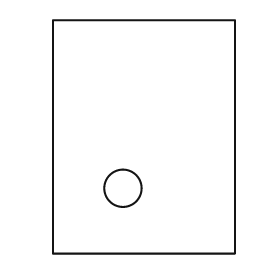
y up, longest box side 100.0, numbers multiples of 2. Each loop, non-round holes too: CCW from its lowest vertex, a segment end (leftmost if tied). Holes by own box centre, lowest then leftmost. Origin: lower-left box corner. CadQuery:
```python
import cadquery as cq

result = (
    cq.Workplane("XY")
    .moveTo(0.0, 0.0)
    .lineTo(78.0, 0.0)
    .lineTo(78.0, 100.0)
    .lineTo(0.0, 100.0)
    .close()
    .moveTo(30.0, 28.0)
    .circle(8.0)
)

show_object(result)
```